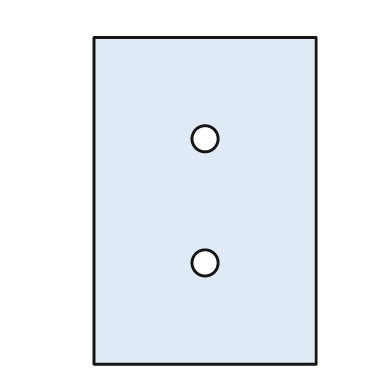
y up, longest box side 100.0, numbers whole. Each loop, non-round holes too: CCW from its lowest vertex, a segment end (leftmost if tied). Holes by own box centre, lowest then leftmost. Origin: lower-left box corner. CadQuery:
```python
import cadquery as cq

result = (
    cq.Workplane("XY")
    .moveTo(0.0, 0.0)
    .lineTo(68.0, 0.0)
    .lineTo(68.0, 100.0)
    .lineTo(0.0, 100.0)
    .close()
    .moveTo(34.0, 31.0)
    .circle(4.0)
    .moveTo(34.0, 69.0)
    .circle(4.0)
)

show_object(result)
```